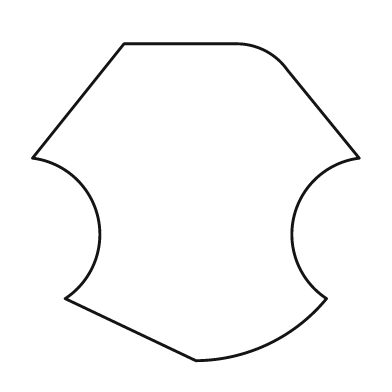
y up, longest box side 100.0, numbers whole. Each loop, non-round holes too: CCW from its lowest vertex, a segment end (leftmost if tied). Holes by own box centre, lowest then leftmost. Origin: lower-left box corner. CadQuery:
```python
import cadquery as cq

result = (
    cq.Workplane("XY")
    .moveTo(50.0, 0.0)
    .threePointArc((72.0, 5.0), (90.0, 19.0))
    .threePointArc((80.0, 44.0), (100.0, 62.0))
    .lineTo(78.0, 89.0)
    .threePointArc((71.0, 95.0), (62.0, 97.0))
    .lineTo(28.0, 97.0)
    .lineTo(0.0, 62.0)
    .threePointArc((20.0, 44.0), (10.0, 19.0))
    .close()
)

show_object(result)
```